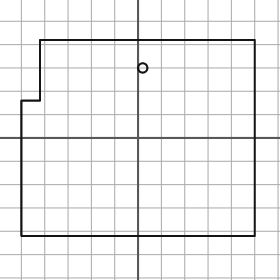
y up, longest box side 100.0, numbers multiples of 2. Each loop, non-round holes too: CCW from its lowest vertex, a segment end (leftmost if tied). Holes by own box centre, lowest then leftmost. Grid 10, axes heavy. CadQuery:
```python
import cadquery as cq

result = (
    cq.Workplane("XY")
    .moveTo(-50.0, -42.0)
    .lineTo(50.0, -42.0)
    .lineTo(50.0, 42.0)
    .lineTo(-42.0, 42.0)
    .lineTo(-42.0, 16.0)
    .lineTo(-50.0, 16.0)
    .close()
    .moveTo(2.0, 30.0)
    .circle(2.0)
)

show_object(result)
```